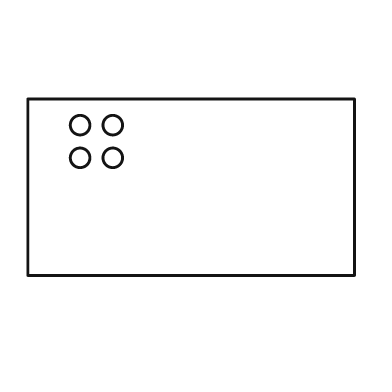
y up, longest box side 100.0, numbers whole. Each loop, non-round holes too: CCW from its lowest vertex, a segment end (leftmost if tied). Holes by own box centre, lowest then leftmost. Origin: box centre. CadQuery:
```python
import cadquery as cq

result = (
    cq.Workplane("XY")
    .moveTo(-50.0, -27.0)
    .lineTo(50.0, -27.0)
    .lineTo(50.0, 27.0)
    .lineTo(-50.0, 27.0)
    .close()
    .moveTo(-34.0, 9.0)
    .circle(3.0)
    .moveTo(-24.0, 9.0)
    .circle(3.0)
    .moveTo(-34.0, 19.0)
    .circle(3.0)
    .moveTo(-24.0, 19.0)
    .circle(3.0)
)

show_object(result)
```